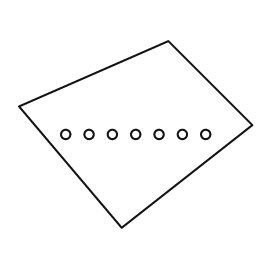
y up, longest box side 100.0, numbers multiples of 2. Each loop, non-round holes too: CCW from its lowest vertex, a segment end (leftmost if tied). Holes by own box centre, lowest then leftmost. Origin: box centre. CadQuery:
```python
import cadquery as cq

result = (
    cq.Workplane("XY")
    .moveTo(-6.0, -40.0)
    .lineTo(50.0, 4.0)
    .lineTo(14.0, 40.0)
    .lineTo(-50.0, 12.0)
    .close()
    .moveTo(-30.0, 0.0)
    .circle(2.0)
    .moveTo(-20.0, 0.0)
    .circle(2.0)
    .moveTo(-10.0, 0.0)
    .circle(2.0)
    .moveTo(0.0, 0.0)
    .circle(2.0)
    .moveTo(10.0, 0.0)
    .circle(2.0)
    .moveTo(20.0, 0.0)
    .circle(2.0)
    .moveTo(30.0, 0.0)
    .circle(2.0)
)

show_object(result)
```